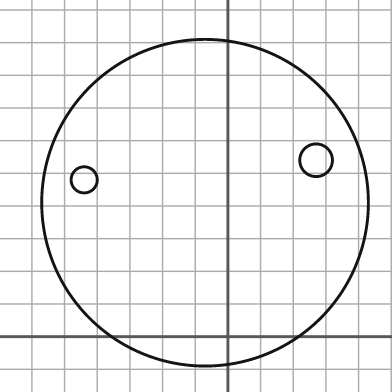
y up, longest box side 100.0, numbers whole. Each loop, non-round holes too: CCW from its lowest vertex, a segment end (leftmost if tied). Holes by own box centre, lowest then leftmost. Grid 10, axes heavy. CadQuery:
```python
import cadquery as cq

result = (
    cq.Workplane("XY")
    .moveTo(-7.0, 41.0)
    .circle(50.0)
    .moveTo(-44.0, 48.0)
    .circle(4.0)
    .moveTo(27.0, 54.0)
    .circle(5.0)
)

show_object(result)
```